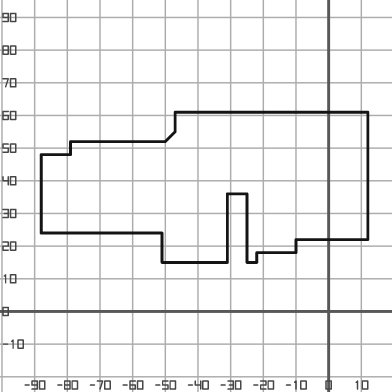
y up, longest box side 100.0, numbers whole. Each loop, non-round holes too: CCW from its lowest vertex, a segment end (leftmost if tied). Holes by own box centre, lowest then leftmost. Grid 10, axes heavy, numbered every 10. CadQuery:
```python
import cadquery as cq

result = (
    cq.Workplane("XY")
    .moveTo(-51.0, 15.0)
    .lineTo(-31.0, 15.0)
    .lineTo(-31.0, 36.0)
    .lineTo(-25.0, 36.0)
    .lineTo(-25.0, 15.0)
    .lineTo(-22.0, 15.0)
    .lineTo(-22.0, 18.0)
    .lineTo(-10.0, 18.0)
    .lineTo(-10.0, 22.0)
    .lineTo(12.0, 22.0)
    .lineTo(12.0, 61.0)
    .lineTo(-47.0, 61.0)
    .lineTo(-47.0, 55.0)
    .lineTo(-50.0, 52.0)
    .lineTo(-79.0, 52.0)
    .lineTo(-79.0, 48.0)
    .lineTo(-88.0, 48.0)
    .lineTo(-88.0, 24.0)
    .lineTo(-51.0, 24.0)
    .close()
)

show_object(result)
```